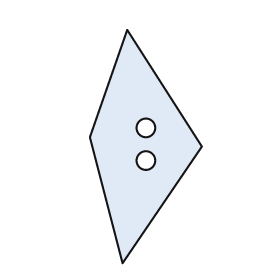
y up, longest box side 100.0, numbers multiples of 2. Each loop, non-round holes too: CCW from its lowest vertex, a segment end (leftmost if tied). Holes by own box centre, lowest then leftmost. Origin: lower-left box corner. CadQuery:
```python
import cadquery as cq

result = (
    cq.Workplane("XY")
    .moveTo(14.0, 0.0)
    .lineTo(48.0, 50.0)
    .lineTo(16.0, 100.0)
    .lineTo(0.0, 54.0)
    .close()
    .moveTo(24.0, 44.0)
    .circle(4.0)
    .moveTo(24.0, 58.0)
    .circle(4.0)
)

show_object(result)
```